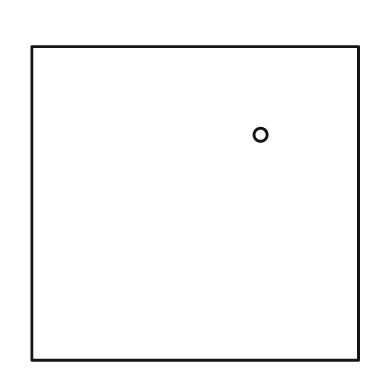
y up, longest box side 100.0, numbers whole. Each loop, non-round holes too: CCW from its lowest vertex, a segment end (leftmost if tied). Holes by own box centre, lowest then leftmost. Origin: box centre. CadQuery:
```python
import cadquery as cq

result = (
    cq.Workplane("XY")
    .moveTo(-50.0, -48.0)
    .lineTo(50.0, -48.0)
    .lineTo(50.0, 48.0)
    .lineTo(-50.0, 48.0)
    .close()
    .moveTo(20.0, 21.0)
    .circle(2.0)
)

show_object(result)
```